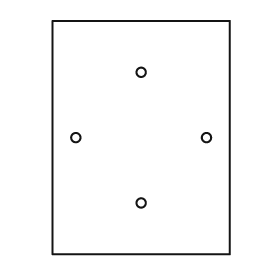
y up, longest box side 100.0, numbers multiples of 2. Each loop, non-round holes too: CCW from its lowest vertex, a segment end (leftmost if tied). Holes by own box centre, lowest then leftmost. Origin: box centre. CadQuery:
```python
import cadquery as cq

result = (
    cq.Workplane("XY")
    .moveTo(-38.0, -50.0)
    .lineTo(38.0, -50.0)
    .lineTo(38.0, 50.0)
    .lineTo(-38.0, 50.0)
    .close()
    .moveTo(0.0, -28.0)
    .circle(2.0)
    .moveTo(-28.0, 0.0)
    .circle(2.0)
    .moveTo(28.0, 0.0)
    .circle(2.0)
    .moveTo(0.0, 28.0)
    .circle(2.0)
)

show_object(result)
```